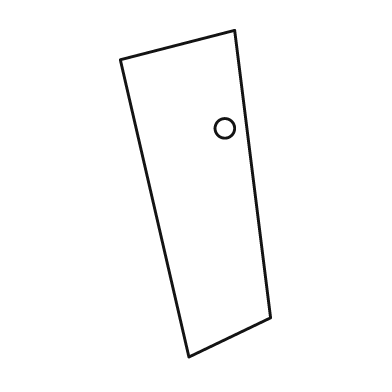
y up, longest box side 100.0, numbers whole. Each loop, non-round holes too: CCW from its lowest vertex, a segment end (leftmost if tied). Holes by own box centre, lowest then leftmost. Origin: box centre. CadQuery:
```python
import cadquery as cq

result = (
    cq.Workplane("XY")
    .moveTo(-2.0, -50.0)
    .lineTo(23.0, -38.0)
    .lineTo(12.0, 50.0)
    .lineTo(-23.0, 41.0)
    .close()
    .moveTo(9.0, 20.0)
    .circle(3.0)
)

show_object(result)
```